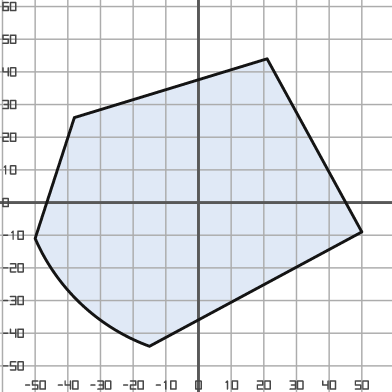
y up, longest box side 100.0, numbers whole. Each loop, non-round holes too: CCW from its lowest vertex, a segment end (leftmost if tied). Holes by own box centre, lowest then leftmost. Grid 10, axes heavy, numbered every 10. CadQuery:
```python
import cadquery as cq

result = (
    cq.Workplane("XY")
    .moveTo(-15.0, -44.0)
    .lineTo(50.0, -9.0)
    .lineTo(21.0, 44.0)
    .lineTo(-38.0, 26.0)
    .lineTo(-50.0, -11.0)
    .threePointArc((-36.0, -31.0), (-15.0, -44.0))
    .close()
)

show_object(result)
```